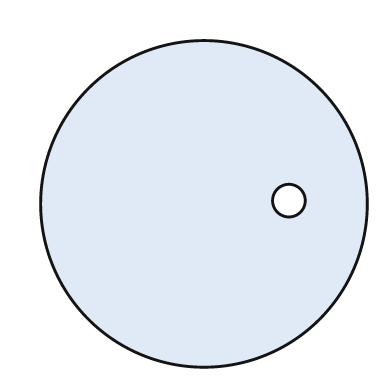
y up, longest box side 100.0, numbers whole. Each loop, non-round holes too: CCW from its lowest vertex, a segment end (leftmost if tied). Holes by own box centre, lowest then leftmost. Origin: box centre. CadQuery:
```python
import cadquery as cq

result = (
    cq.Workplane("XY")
    .moveTo(0.0, 0.0)
    .circle(50.0)
    .moveTo(26.0, 1.0)
    .circle(5.0)
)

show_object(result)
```